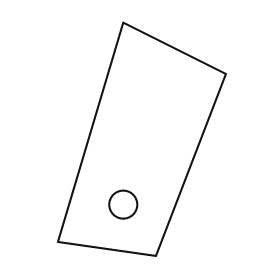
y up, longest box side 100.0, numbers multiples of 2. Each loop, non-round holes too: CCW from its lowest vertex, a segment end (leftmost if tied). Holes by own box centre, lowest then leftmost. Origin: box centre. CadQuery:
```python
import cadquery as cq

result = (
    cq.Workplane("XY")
    .moveTo(6.0, -50.0)
    .lineTo(36.0, 28.0)
    .lineTo(-8.0, 50.0)
    .lineTo(-36.0, -44.0)
    .close()
    .moveTo(-8.0, -28.0)
    .circle(6.0)
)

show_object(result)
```